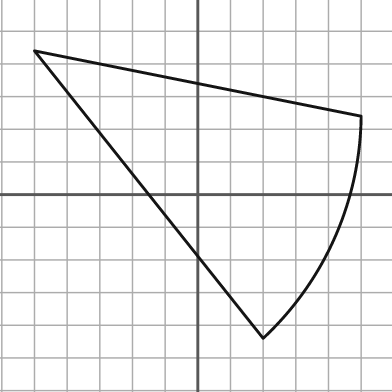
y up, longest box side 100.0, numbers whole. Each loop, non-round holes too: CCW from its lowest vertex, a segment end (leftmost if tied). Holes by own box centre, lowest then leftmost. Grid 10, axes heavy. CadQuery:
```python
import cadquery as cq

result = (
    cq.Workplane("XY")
    .moveTo(20.0, -44.0)
    .threePointArc((42.0, -13.0), (50.0, 24.0))
    .lineTo(-50.0, 44.0)
    .close()
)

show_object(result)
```